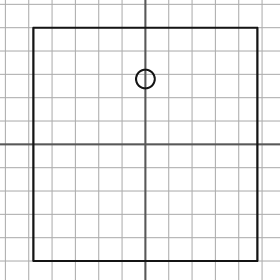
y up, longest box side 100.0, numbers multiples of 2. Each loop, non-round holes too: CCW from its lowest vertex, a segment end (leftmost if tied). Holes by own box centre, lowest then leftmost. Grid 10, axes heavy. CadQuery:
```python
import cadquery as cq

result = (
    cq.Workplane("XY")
    .moveTo(-48.0, -50.0)
    .lineTo(48.0, -50.0)
    .lineTo(48.0, 50.0)
    .lineTo(-48.0, 50.0)
    .close()
    .moveTo(0.0, 28.0)
    .circle(4.0)
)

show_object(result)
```